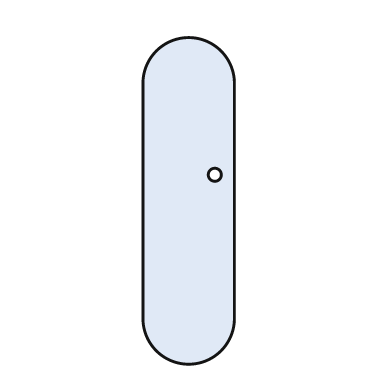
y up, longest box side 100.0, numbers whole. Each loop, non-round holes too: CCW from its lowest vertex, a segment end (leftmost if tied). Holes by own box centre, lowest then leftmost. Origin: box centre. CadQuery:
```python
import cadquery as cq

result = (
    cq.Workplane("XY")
    .moveTo(-14.0, -36.0)
    .threePointArc((0.0, -50.0), (14.0, -36.0))
    .lineTo(14.0, 36.0)
    .threePointArc((0.0, 50.0), (-14.0, 36.0))
    .close()
    .moveTo(8.0, 8.0)
    .circle(2.0)
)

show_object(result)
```